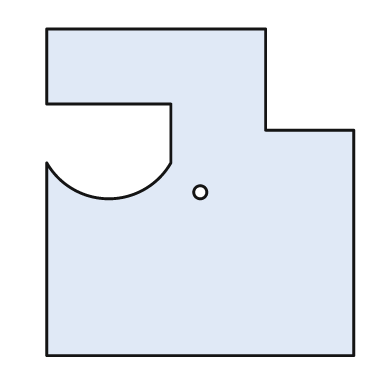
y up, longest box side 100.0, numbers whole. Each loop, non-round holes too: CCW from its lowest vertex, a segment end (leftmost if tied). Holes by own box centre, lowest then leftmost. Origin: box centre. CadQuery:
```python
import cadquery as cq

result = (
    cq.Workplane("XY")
    .moveTo(-47.0, -50.0)
    .lineTo(47.0, -50.0)
    .lineTo(47.0, 19.0)
    .lineTo(20.0, 19.0)
    .lineTo(20.0, 50.0)
    .lineTo(-47.0, 50.0)
    .lineTo(-47.0, 27.0)
    .lineTo(-9.0, 27.0)
    .lineTo(-9.0, 9.0)
    .threePointArc((-28.0, -2.0), (-47.0, 9.0))
    .close()
    .moveTo(0.0, 0.0)
    .circle(2.0)
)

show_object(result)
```